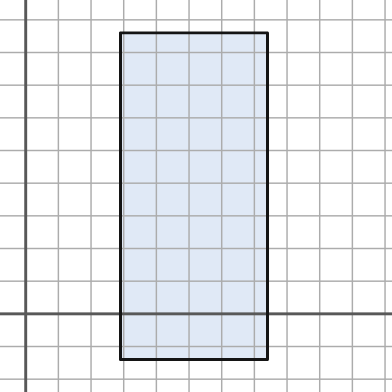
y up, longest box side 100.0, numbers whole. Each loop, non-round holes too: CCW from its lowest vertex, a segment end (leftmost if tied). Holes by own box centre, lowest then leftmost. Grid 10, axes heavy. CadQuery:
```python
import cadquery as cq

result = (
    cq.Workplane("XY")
    .moveTo(29.0, -14.0)
    .lineTo(74.0, -14.0)
    .lineTo(74.0, 86.0)
    .lineTo(29.0, 86.0)
    .close()
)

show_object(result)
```